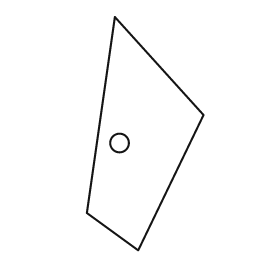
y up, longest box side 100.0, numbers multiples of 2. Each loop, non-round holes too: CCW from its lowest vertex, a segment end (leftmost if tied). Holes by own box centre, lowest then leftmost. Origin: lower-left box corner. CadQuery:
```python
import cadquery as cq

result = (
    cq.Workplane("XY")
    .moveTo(22.0, 0.0)
    .lineTo(50.0, 58.0)
    .lineTo(12.0, 100.0)
    .lineTo(0.0, 16.0)
    .close()
    .moveTo(14.0, 46.0)
    .circle(4.0)
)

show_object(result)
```